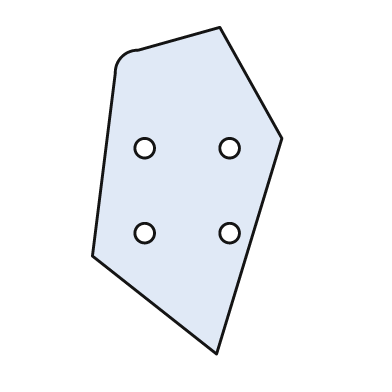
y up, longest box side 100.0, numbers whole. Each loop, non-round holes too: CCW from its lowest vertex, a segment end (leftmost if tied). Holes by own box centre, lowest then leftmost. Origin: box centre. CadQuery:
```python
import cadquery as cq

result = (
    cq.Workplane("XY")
    .moveTo(9.0, -50.0)
    .lineTo(29.0, 16.0)
    .lineTo(10.0, 50.0)
    .lineTo(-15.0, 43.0)
    .threePointArc((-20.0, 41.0), (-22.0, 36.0))
    .lineTo(-29.0, -20.0)
    .close()
    .moveTo(-13.0, -13.0)
    .circle(3.0)
    .moveTo(13.0, -13.0)
    .circle(3.0)
    .moveTo(-13.0, 13.0)
    .circle(3.0)
    .moveTo(13.0, 13.0)
    .circle(3.0)
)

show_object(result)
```